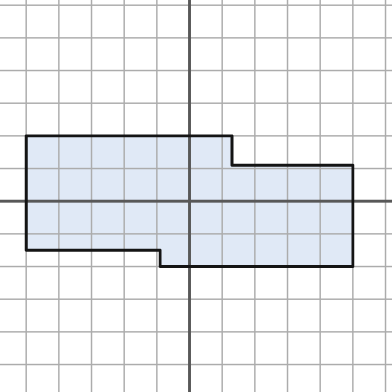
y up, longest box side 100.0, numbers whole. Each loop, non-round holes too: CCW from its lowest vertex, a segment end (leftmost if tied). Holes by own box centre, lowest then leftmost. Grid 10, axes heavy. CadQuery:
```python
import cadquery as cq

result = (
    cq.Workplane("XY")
    .moveTo(-9.0, -20.0)
    .lineTo(50.0, -20.0)
    .lineTo(50.0, 11.0)
    .lineTo(13.0, 11.0)
    .lineTo(13.0, 20.0)
    .lineTo(-50.0, 20.0)
    .lineTo(-50.0, -15.0)
    .lineTo(-9.0, -15.0)
    .close()
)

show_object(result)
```